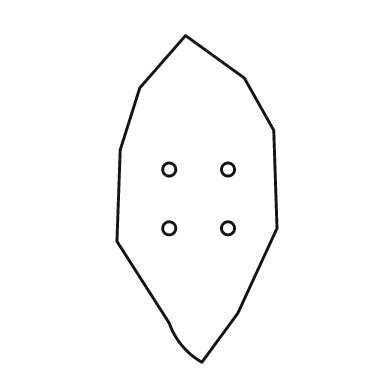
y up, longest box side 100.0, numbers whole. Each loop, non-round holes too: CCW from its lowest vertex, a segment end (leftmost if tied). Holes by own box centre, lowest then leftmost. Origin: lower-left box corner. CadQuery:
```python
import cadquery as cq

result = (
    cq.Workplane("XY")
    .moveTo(26.0, 0.0)
    .lineTo(37.0, 15.0)
    .lineTo(49.0, 41.0)
    .lineTo(48.0, 71.0)
    .lineTo(39.0, 87.0)
    .lineTo(21.0, 100.0)
    .lineTo(7.0, 84.0)
    .lineTo(1.0, 65.0)
    .lineTo(0.0, 37.0)
    .lineTo(16.0, 12.0)
    .threePointArc((20.0, 5.0), (26.0, 0.0))
    .close()
    .moveTo(16.0, 41.0)
    .circle(2.0)
    .moveTo(34.0, 41.0)
    .circle(2.0)
    .moveTo(16.0, 59.0)
    .circle(2.0)
    .moveTo(34.0, 59.0)
    .circle(2.0)
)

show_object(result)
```